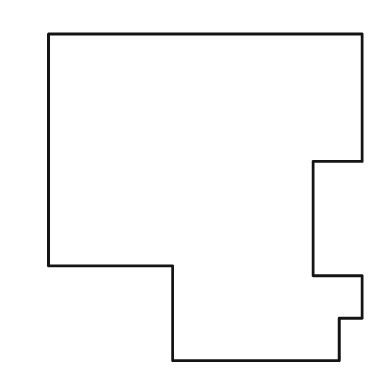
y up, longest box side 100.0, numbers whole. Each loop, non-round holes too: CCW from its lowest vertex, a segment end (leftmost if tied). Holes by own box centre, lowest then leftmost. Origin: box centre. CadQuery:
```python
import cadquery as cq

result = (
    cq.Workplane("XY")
    .moveTo(-10.0, -50.0)
    .lineTo(41.0, -50.0)
    .lineTo(41.0, -37.0)
    .lineTo(48.0, -37.0)
    .lineTo(48.0, -24.0)
    .lineTo(33.0, -24.0)
    .lineTo(33.0, 11.0)
    .lineTo(48.0, 11.0)
    .lineTo(48.0, 50.0)
    .lineTo(-48.0, 50.0)
    .lineTo(-48.0, -21.0)
    .lineTo(-10.0, -21.0)
    .close()
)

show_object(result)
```